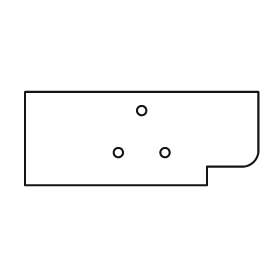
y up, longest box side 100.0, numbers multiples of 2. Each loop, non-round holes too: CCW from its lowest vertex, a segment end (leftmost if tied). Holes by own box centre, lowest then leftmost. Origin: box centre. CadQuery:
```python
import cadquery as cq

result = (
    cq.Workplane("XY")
    .moveTo(-50.0, -20.0)
    .lineTo(28.0, -20.0)
    .lineTo(28.0, -12.0)
    .lineTo(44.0, -12.0)
    .threePointArc((48.0, -10.0), (50.0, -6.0))
    .lineTo(50.0, 20.0)
    .lineTo(-50.0, 20.0)
    .close()
    .moveTo(-10.0, -6.0)
    .circle(2.0)
    .moveTo(10.0, -6.0)
    .circle(2.0)
    .moveTo(0.0, 12.0)
    .circle(2.0)
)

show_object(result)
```